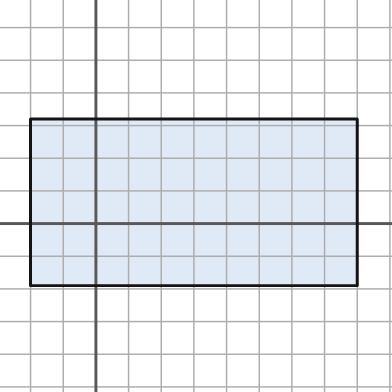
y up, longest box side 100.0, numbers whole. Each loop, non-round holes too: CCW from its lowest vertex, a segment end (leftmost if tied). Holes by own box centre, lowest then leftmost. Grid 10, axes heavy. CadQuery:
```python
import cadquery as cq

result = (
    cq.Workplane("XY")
    .moveTo(-20.0, -19.0)
    .lineTo(80.0, -19.0)
    .lineTo(80.0, 32.0)
    .lineTo(-20.0, 32.0)
    .close()
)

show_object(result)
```